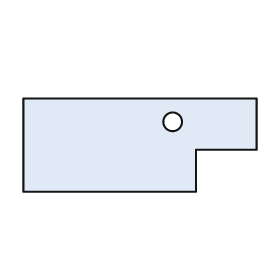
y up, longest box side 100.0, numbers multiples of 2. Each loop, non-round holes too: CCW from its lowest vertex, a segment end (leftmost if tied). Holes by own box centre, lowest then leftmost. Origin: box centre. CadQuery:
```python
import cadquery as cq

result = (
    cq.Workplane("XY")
    .moveTo(-50.0, -20.0)
    .lineTo(24.0, -20.0)
    .lineTo(24.0, -2.0)
    .lineTo(50.0, -2.0)
    .lineTo(50.0, 20.0)
    .lineTo(-50.0, 20.0)
    .close()
    .moveTo(14.0, 10.0)
    .circle(4.0)
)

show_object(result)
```